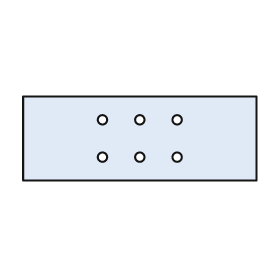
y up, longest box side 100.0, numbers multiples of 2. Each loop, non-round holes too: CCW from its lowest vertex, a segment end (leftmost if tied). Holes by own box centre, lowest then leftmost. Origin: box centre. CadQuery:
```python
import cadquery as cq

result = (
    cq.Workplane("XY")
    .moveTo(-50.0, -18.0)
    .lineTo(50.0, -18.0)
    .lineTo(50.0, 18.0)
    .lineTo(-50.0, 18.0)
    .close()
    .moveTo(-16.0, -8.0)
    .circle(2.0)
    .moveTo(0.0, -8.0)
    .circle(2.0)
    .moveTo(16.0, -8.0)
    .circle(2.0)
    .moveTo(-16.0, 8.0)
    .circle(2.0)
    .moveTo(0.0, 8.0)
    .circle(2.0)
    .moveTo(16.0, 8.0)
    .circle(2.0)
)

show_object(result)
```